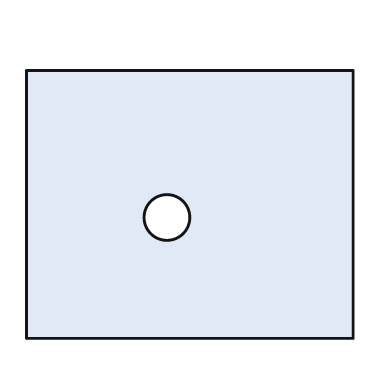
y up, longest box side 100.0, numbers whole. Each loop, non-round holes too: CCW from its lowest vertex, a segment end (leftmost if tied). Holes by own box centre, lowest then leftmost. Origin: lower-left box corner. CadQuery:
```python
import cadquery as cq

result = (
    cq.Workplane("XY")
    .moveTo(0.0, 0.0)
    .lineTo(100.0, 0.0)
    .lineTo(100.0, 82.0)
    .lineTo(0.0, 82.0)
    .close()
    .moveTo(43.0, 37.0)
    .circle(7.0)
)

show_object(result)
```